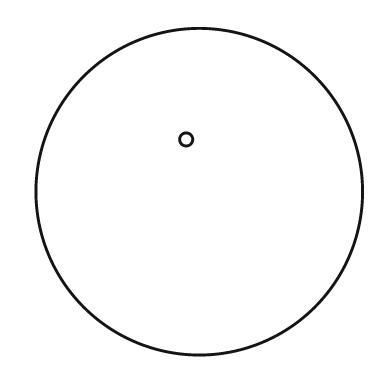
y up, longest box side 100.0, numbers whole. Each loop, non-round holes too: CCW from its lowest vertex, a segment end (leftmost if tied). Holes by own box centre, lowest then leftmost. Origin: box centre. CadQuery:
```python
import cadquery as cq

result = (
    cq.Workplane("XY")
    .moveTo(0.0, 0.0)
    .circle(50.0)
    .moveTo(-4.0, 16.0)
    .circle(2.0)
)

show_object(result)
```